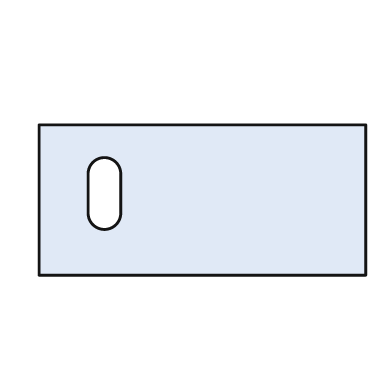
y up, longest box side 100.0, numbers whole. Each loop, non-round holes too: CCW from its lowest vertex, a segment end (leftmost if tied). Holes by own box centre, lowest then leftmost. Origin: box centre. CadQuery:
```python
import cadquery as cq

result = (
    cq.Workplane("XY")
    .moveTo(-50.0, -23.0)
    .lineTo(50.0, -23.0)
    .lineTo(50.0, 23.0)
    .lineTo(-50.0, 23.0)
    .close()
    .moveTo(-35.0, -4.0)
    .threePointArc((-30.0, -9.0), (-25.0, -4.0))
    .lineTo(-25.0, 8.0)
    .threePointArc((-30.0, 13.0), (-35.0, 8.0))
    .close()
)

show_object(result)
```